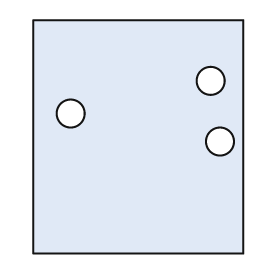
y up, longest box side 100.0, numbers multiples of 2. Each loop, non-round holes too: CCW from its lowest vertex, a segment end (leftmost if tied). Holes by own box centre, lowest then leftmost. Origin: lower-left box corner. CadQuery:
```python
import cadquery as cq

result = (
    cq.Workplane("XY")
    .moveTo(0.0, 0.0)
    .lineTo(90.0, 0.0)
    .lineTo(90.0, 100.0)
    .lineTo(0.0, 100.0)
    .close()
    .moveTo(80.0, 48.0)
    .circle(6.0)
    .moveTo(16.0, 60.0)
    .circle(6.0)
    .moveTo(76.0, 74.0)
    .circle(6.0)
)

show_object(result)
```